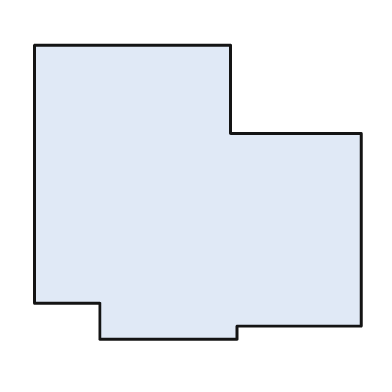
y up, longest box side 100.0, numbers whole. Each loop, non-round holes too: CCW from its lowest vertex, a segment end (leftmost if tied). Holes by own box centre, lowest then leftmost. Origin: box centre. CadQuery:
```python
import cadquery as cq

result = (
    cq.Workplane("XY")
    .moveTo(-30.0, -45.0)
    .lineTo(12.0, -45.0)
    .lineTo(12.0, -41.0)
    .lineTo(50.0, -41.0)
    .lineTo(50.0, 18.0)
    .lineTo(10.0, 18.0)
    .lineTo(10.0, 45.0)
    .lineTo(-50.0, 45.0)
    .lineTo(-50.0, -34.0)
    .lineTo(-30.0, -34.0)
    .close()
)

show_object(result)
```